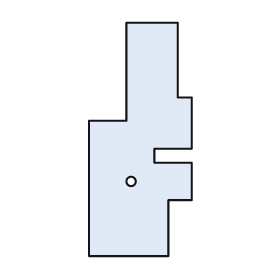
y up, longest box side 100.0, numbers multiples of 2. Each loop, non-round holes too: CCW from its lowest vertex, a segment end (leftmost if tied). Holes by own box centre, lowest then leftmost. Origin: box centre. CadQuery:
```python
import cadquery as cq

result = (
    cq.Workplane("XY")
    .moveTo(-22.0, -50.0)
    .lineTo(12.0, -50.0)
    .lineTo(12.0, -26.0)
    .lineTo(22.0, -26.0)
    .lineTo(22.0, -10.0)
    .lineTo(6.0, -10.0)
    .lineTo(6.0, -4.0)
    .lineTo(22.0, -4.0)
    .lineTo(22.0, 18.0)
    .lineTo(16.0, 18.0)
    .lineTo(16.0, 50.0)
    .lineTo(-6.0, 50.0)
    .lineTo(-6.0, 8.0)
    .lineTo(-22.0, 8.0)
    .close()
    .moveTo(-4.0, -18.0)
    .circle(2.0)
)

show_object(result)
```